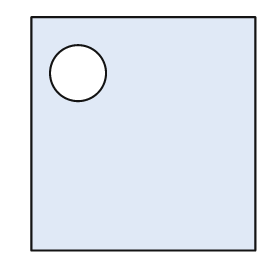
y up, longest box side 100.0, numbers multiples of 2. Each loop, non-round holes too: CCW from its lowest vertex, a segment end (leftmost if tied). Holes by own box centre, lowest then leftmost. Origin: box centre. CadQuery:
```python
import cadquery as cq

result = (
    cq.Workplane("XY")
    .moveTo(-48.0, -50.0)
    .lineTo(48.0, -50.0)
    .lineTo(48.0, 50.0)
    .lineTo(-48.0, 50.0)
    .close()
    .moveTo(-28.0, 26.0)
    .circle(12.0)
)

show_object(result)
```